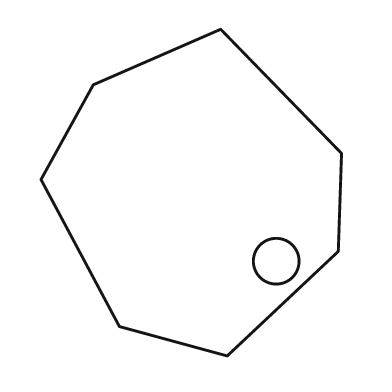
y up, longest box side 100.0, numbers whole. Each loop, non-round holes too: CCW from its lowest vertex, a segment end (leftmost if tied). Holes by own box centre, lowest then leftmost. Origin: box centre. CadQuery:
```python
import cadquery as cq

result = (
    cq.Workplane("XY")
    .moveTo(11.0, -50.0)
    .lineTo(45.0, -18.0)
    .lineTo(46.0, 12.0)
    .lineTo(9.0, 50.0)
    .lineTo(-30.0, 33.0)
    .lineTo(-46.0, 4.0)
    .lineTo(-22.0, -41.0)
    .close()
    .moveTo(26.0, -21.0)
    .circle(7.0)
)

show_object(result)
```